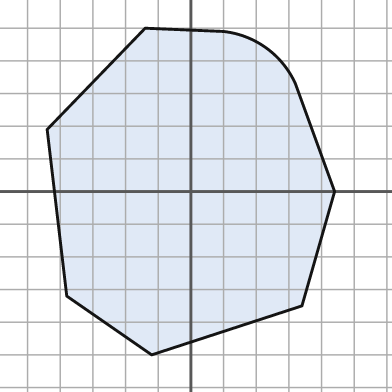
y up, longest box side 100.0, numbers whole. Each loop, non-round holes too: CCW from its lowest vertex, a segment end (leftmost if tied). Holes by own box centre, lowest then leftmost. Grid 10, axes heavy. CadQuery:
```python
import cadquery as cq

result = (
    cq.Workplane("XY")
    .moveTo(-12.0, -50.0)
    .lineTo(34.0, -35.0)
    .lineTo(44.0, 0.0)
    .lineTo(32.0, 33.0)
    .threePointArc((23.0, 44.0), (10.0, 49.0))
    .lineTo(-14.0, 50.0)
    .lineTo(-44.0, 19.0)
    .lineTo(-38.0, -32.0)
    .close()
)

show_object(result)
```